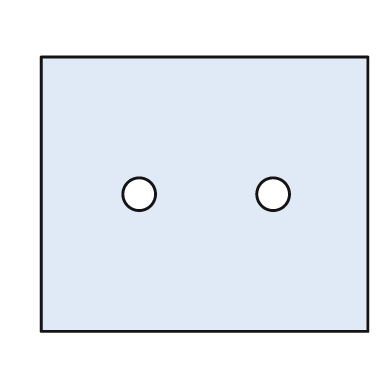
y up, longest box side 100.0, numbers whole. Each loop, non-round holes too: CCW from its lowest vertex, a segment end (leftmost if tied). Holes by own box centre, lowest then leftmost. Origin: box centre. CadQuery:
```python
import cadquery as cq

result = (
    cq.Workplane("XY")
    .moveTo(-50.0, -42.0)
    .lineTo(50.0, -42.0)
    .lineTo(50.0, 42.0)
    .lineTo(-50.0, 42.0)
    .close()
    .moveTo(-20.0, 0.0)
    .circle(5.0)
    .moveTo(21.0, 0.0)
    .circle(5.0)
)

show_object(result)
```